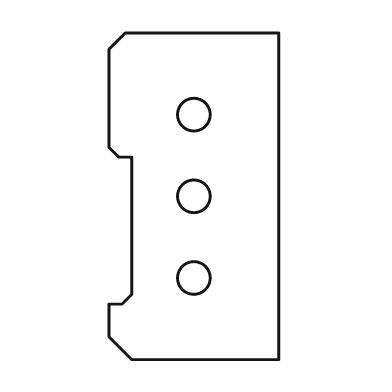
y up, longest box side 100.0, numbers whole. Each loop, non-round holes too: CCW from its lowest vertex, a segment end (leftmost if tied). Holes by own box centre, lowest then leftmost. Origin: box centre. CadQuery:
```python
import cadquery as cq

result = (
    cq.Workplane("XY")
    .moveTo(-19.0, -50.0)
    .lineTo(26.0, -50.0)
    .lineTo(26.0, 50.0)
    .lineTo(-21.0, 50.0)
    .lineTo(-26.0, 45.0)
    .lineTo(-26.0, 15.0)
    .lineTo(-23.0, 12.0)
    .lineTo(-19.0, 12.0)
    .lineTo(-19.0, -30.0)
    .lineTo(-22.0, -33.0)
    .lineTo(-26.0, -33.0)
    .lineTo(-26.0, -43.0)
    .close()
    .moveTo(0.0, -25.0)
    .circle(5.0)
    .moveTo(0.0, 0.0)
    .circle(5.0)
    .moveTo(0.0, 25.0)
    .circle(5.0)
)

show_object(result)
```